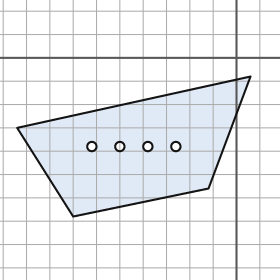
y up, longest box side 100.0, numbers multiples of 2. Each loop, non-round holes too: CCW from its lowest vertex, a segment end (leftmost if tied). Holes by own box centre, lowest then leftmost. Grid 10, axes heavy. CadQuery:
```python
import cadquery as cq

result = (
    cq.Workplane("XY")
    .moveTo(-70.0, -68.0)
    .lineTo(-12.0, -56.0)
    .lineTo(6.0, -8.0)
    .lineTo(-94.0, -30.0)
    .close()
    .moveTo(-62.0, -38.0)
    .circle(2.0)
    .moveTo(-50.0, -38.0)
    .circle(2.0)
    .moveTo(-38.0, -38.0)
    .circle(2.0)
    .moveTo(-26.0, -38.0)
    .circle(2.0)
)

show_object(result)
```